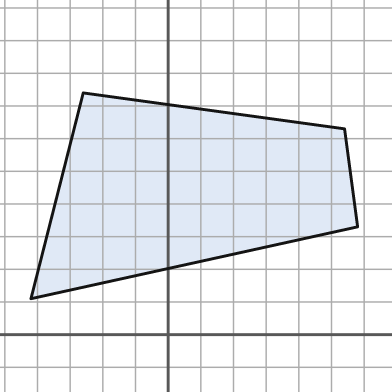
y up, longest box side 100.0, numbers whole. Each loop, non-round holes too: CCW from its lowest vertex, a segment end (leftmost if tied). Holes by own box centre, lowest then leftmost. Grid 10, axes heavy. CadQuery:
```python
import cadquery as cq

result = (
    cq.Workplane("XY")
    .moveTo(-42.0, 11.0)
    .lineTo(58.0, 33.0)
    .lineTo(54.0, 63.0)
    .lineTo(-26.0, 74.0)
    .close()
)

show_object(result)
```